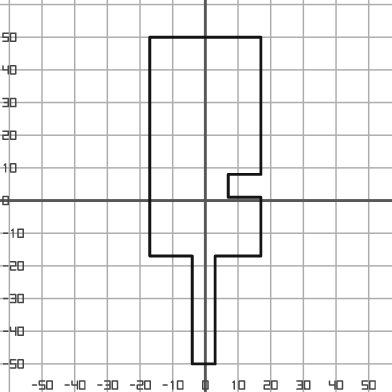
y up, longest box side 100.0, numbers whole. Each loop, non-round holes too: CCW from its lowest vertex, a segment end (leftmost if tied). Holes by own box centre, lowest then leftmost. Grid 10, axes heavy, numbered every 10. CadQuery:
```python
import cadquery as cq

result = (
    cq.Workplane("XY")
    .moveTo(-4.0, -50.0)
    .lineTo(3.0, -50.0)
    .lineTo(3.0, -17.0)
    .lineTo(17.0, -17.0)
    .lineTo(17.0, 1.0)
    .lineTo(7.0, 1.0)
    .lineTo(7.0, 8.0)
    .lineTo(17.0, 8.0)
    .lineTo(17.0, 50.0)
    .lineTo(-17.0, 50.0)
    .lineTo(-17.0, -17.0)
    .lineTo(-4.0, -17.0)
    .close()
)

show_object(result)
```